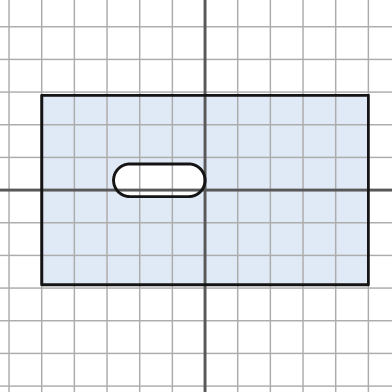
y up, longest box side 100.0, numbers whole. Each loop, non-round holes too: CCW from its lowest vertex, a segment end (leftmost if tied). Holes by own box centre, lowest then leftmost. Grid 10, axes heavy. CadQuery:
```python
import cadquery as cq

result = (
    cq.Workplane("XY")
    .moveTo(-50.0, -29.0)
    .lineTo(50.0, -29.0)
    .lineTo(50.0, 29.0)
    .lineTo(-50.0, 29.0)
    .close()
    .moveTo(-23.0, -2.0)
    .lineTo(-5.0, -2.0)
    .threePointArc((0.0, 3.0), (-5.0, 8.0))
    .lineTo(-23.0, 8.0)
    .threePointArc((-28.0, 3.0), (-23.0, -2.0))
    .close()
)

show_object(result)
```